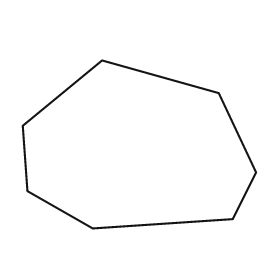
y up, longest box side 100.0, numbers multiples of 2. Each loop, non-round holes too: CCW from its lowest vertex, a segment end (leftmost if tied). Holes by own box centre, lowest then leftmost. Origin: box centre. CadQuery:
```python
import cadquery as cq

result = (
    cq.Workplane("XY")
    .moveTo(-20.0, -36.0)
    .lineTo(40.0, -32.0)
    .lineTo(50.0, -12.0)
    .lineTo(34.0, 22.0)
    .lineTo(-16.0, 36.0)
    .lineTo(-50.0, 8.0)
    .lineTo(-48.0, -20.0)
    .close()
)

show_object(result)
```